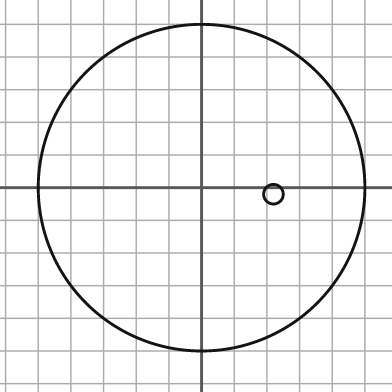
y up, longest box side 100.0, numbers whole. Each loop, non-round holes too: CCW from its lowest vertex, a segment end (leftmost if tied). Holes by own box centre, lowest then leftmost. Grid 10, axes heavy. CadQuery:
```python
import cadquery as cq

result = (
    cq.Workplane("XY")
    .moveTo(0.0, 0.0)
    .circle(50.0)
    .moveTo(22.0, -2.0)
    .circle(3.0)
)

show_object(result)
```